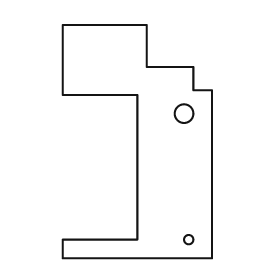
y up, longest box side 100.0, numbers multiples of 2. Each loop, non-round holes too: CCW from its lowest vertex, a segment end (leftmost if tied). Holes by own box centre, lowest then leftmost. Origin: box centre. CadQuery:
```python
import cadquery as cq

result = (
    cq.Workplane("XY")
    .moveTo(-32.0, -50.0)
    .lineTo(32.0, -50.0)
    .lineTo(32.0, 22.0)
    .lineTo(24.0, 22.0)
    .lineTo(24.0, 32.0)
    .lineTo(4.0, 32.0)
    .lineTo(4.0, 50.0)
    .lineTo(-32.0, 50.0)
    .lineTo(-32.0, 20.0)
    .lineTo(0.0, 20.0)
    .lineTo(0.0, -42.0)
    .lineTo(-32.0, -42.0)
    .close()
    .moveTo(22.0, -42.0)
    .circle(2.0)
    .moveTo(20.0, 12.0)
    .circle(4.0)
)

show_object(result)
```